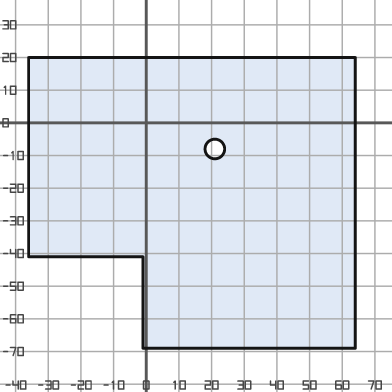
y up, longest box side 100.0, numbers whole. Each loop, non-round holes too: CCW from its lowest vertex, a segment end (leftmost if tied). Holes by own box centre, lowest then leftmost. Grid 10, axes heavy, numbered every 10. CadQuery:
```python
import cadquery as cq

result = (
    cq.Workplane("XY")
    .moveTo(-1.0, -69.0)
    .lineTo(64.0, -69.0)
    .lineTo(64.0, 20.0)
    .lineTo(-36.0, 20.0)
    .lineTo(-36.0, -41.0)
    .lineTo(-1.0, -41.0)
    .close()
    .moveTo(21.0, -8.0)
    .circle(3.0)
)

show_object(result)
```